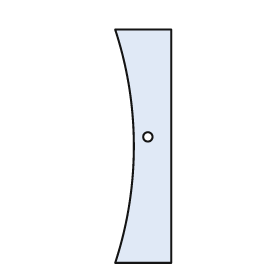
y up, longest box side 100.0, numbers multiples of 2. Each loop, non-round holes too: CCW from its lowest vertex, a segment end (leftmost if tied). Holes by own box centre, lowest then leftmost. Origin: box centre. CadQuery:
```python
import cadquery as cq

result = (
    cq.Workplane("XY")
    .moveTo(-12.0, -50.0)
    .lineTo(12.0, -50.0)
    .lineTo(12.0, 50.0)
    .lineTo(-12.0, 50.0)
    .threePointArc((-4.0, 0.0), (-12.0, -50.0))
    .close()
    .moveTo(2.0, 4.0)
    .circle(2.0)
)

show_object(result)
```